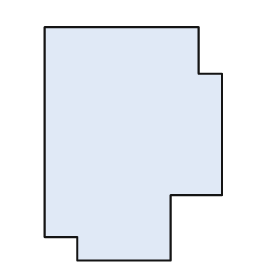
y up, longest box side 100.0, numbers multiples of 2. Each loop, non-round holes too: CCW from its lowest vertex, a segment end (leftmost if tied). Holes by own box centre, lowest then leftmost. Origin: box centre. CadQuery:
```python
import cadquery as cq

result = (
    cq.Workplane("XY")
    .moveTo(-24.0, -50.0)
    .lineTo(16.0, -50.0)
    .lineTo(16.0, -22.0)
    .lineTo(38.0, -22.0)
    .lineTo(38.0, 30.0)
    .lineTo(28.0, 30.0)
    .lineTo(28.0, 50.0)
    .lineTo(-38.0, 50.0)
    .lineTo(-38.0, -40.0)
    .lineTo(-24.0, -40.0)
    .close()
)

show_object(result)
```